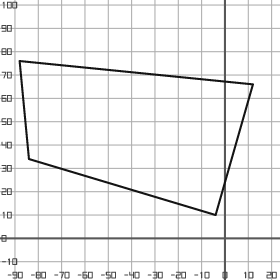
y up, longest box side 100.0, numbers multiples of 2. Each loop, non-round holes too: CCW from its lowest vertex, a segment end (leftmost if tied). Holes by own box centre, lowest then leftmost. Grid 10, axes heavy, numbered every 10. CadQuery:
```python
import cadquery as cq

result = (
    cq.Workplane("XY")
    .moveTo(-4.0, 10.0)
    .lineTo(12.0, 66.0)
    .lineTo(-88.0, 76.0)
    .lineTo(-84.0, 34.0)
    .close()
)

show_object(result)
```